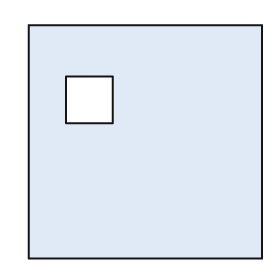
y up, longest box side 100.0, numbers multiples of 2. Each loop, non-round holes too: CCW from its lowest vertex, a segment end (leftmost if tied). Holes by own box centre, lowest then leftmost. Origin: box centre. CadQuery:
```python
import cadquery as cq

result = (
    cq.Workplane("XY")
    .moveTo(-50.0, -50.0)
    .lineTo(50.0, -50.0)
    .lineTo(50.0, 50.0)
    .lineTo(-50.0, 50.0)
    .close()
    .moveTo(-34.0, 8.0)
    .lineTo(-14.0, 8.0)
    .lineTo(-14.0, 28.0)
    .lineTo(-34.0, 28.0)
    .close()
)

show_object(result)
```